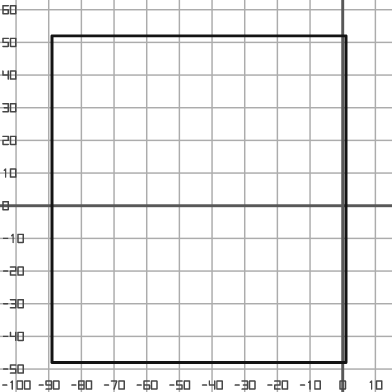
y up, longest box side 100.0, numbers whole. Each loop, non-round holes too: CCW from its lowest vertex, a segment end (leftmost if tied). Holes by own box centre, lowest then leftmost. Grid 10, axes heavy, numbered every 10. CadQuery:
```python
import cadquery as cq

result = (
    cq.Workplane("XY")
    .moveTo(-89.0, -48.0)
    .lineTo(1.0, -48.0)
    .lineTo(1.0, 52.0)
    .lineTo(-89.0, 52.0)
    .close()
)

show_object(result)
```